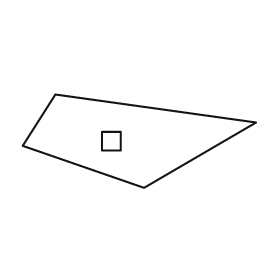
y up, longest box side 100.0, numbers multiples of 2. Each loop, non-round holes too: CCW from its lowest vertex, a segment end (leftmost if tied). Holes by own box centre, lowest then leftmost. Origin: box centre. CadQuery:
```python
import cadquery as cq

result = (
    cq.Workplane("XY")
    .moveTo(2.0, -20.0)
    .lineTo(50.0, 8.0)
    .lineTo(-36.0, 20.0)
    .lineTo(-50.0, -2.0)
    .close()
    .moveTo(-16.0, -4.0)
    .lineTo(-8.0, -4.0)
    .lineTo(-8.0, 4.0)
    .lineTo(-16.0, 4.0)
    .close()
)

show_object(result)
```